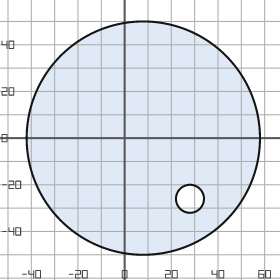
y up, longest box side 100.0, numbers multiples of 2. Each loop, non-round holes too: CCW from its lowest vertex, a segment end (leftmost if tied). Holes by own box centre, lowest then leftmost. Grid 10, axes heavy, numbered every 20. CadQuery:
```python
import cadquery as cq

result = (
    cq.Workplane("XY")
    .moveTo(8.0, 0.0)
    .circle(50.0)
    .moveTo(28.0, -26.0)
    .circle(6.0)
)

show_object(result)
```